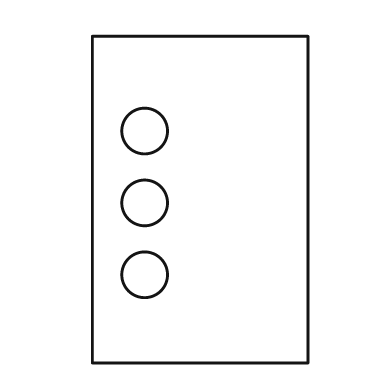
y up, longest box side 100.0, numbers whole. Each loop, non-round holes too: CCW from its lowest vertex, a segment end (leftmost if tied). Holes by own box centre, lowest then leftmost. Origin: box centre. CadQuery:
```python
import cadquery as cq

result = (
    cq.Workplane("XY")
    .moveTo(-33.0, -50.0)
    .lineTo(33.0, -50.0)
    .lineTo(33.0, 50.0)
    .lineTo(-33.0, 50.0)
    .close()
    .moveTo(-17.0, -23.0)
    .circle(7.0)
    .moveTo(-17.0, -1.0)
    .circle(7.0)
    .moveTo(-17.0, 21.0)
    .circle(7.0)
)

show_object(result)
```